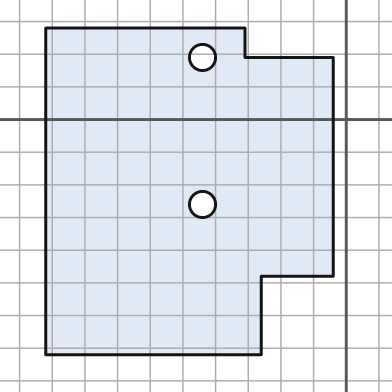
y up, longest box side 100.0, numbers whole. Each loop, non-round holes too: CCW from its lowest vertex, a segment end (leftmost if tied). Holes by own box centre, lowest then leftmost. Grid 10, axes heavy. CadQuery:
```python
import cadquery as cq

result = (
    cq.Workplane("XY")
    .moveTo(-92.0, -72.0)
    .lineTo(-26.0, -72.0)
    .lineTo(-26.0, -48.0)
    .lineTo(-4.0, -48.0)
    .lineTo(-4.0, 19.0)
    .lineTo(-31.0, 19.0)
    .lineTo(-31.0, 28.0)
    .lineTo(-92.0, 28.0)
    .close()
    .moveTo(-44.0, -26.0)
    .circle(4.0)
    .moveTo(-44.0, 19.0)
    .circle(4.0)
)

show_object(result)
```